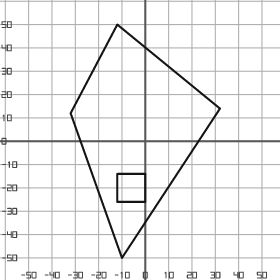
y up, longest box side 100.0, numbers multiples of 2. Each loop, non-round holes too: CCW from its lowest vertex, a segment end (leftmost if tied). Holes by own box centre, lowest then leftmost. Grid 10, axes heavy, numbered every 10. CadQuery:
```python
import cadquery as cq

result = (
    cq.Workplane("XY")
    .moveTo(-10.0, -50.0)
    .lineTo(32.0, 14.0)
    .lineTo(-12.0, 50.0)
    .lineTo(-32.0, 12.0)
    .close()
    .moveTo(-12.0, -26.0)
    .lineTo(0.0, -26.0)
    .lineTo(0.0, -14.0)
    .lineTo(-12.0, -14.0)
    .close()
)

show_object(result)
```